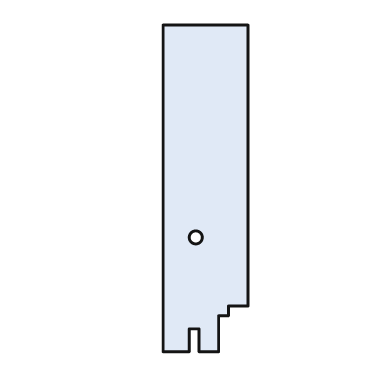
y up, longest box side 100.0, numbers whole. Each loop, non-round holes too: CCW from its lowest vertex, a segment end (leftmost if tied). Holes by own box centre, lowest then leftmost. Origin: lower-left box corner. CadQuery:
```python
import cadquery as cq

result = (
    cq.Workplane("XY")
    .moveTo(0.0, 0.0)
    .lineTo(8.0, 0.0)
    .lineTo(8.0, 7.0)
    .lineTo(11.0, 7.0)
    .lineTo(11.0, 0.0)
    .lineTo(17.0, 0.0)
    .lineTo(17.0, 11.0)
    .lineTo(20.0, 11.0)
    .lineTo(20.0, 14.0)
    .lineTo(26.0, 14.0)
    .lineTo(26.0, 100.0)
    .lineTo(0.0, 100.0)
    .close()
    .moveTo(10.0, 35.0)
    .circle(2.0)
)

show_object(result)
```